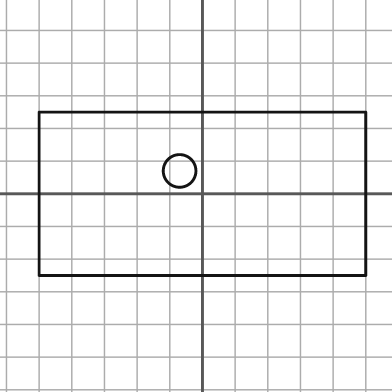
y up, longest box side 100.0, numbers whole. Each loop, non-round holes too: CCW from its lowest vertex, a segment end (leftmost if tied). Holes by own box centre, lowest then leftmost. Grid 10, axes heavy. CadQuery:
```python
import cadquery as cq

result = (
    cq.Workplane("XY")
    .moveTo(-50.0, -25.0)
    .lineTo(50.0, -25.0)
    .lineTo(50.0, 25.0)
    .lineTo(-50.0, 25.0)
    .close()
    .moveTo(-7.0, 7.0)
    .circle(5.0)
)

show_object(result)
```